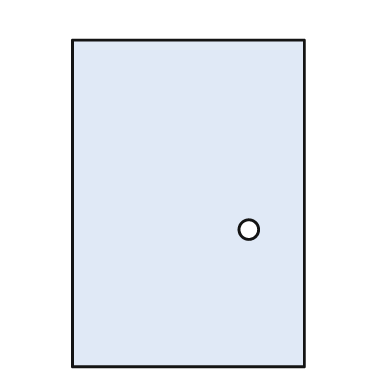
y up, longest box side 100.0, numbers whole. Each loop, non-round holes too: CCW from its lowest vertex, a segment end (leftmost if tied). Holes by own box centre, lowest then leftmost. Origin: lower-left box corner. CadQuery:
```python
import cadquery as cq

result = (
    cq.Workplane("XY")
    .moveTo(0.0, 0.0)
    .lineTo(71.0, 0.0)
    .lineTo(71.0, 100.0)
    .lineTo(0.0, 100.0)
    .close()
    .moveTo(54.0, 42.0)
    .circle(3.0)
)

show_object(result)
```